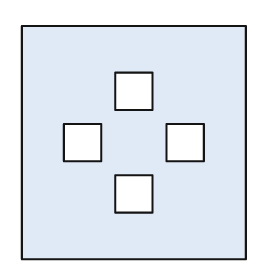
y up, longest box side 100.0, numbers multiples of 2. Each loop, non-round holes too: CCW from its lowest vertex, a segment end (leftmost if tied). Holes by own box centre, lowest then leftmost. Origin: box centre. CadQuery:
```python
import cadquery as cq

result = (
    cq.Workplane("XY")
    .moveTo(-48.0, -50.0)
    .lineTo(48.0, -50.0)
    .lineTo(48.0, 50.0)
    .lineTo(-48.0, 50.0)
    .close()
    .moveTo(-8.0, -30.0)
    .lineTo(8.0, -30.0)
    .lineTo(8.0, -14.0)
    .lineTo(-8.0, -14.0)
    .close()
    .moveTo(-30.0, -8.0)
    .lineTo(-14.0, -8.0)
    .lineTo(-14.0, 8.0)
    .lineTo(-30.0, 8.0)
    .close()
    .moveTo(14.0, -8.0)
    .lineTo(30.0, -8.0)
    .lineTo(30.0, 8.0)
    .lineTo(14.0, 8.0)
    .close()
    .moveTo(-8.0, 14.0)
    .lineTo(8.0, 14.0)
    .lineTo(8.0, 30.0)
    .lineTo(-8.0, 30.0)
    .close()
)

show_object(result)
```